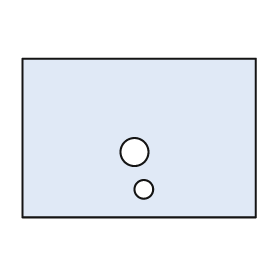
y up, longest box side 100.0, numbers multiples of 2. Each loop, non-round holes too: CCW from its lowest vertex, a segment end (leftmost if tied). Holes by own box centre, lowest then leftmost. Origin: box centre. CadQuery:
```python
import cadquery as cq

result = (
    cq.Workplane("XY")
    .moveTo(-50.0, -34.0)
    .lineTo(50.0, -34.0)
    .lineTo(50.0, 34.0)
    .lineTo(-50.0, 34.0)
    .close()
    .moveTo(2.0, -22.0)
    .circle(4.0)
    .moveTo(-2.0, -6.0)
    .circle(6.0)
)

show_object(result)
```